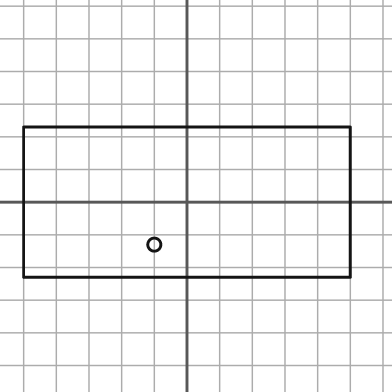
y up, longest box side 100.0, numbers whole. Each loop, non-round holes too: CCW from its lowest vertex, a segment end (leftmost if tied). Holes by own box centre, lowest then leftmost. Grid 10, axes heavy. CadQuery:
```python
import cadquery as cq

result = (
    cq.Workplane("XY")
    .moveTo(-50.0, -23.0)
    .lineTo(50.0, -23.0)
    .lineTo(50.0, 23.0)
    .lineTo(-50.0, 23.0)
    .close()
    .moveTo(-10.0, -13.0)
    .circle(2.0)
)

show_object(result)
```